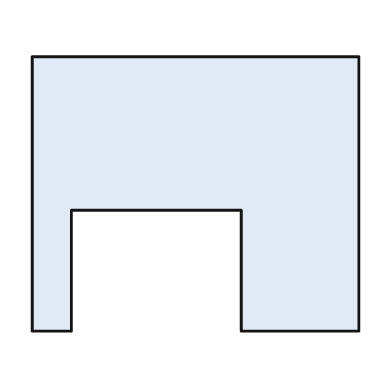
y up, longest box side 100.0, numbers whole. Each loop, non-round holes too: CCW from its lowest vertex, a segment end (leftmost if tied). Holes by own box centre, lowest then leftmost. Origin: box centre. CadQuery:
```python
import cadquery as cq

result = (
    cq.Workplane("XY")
    .moveTo(-50.0, -42.0)
    .lineTo(-38.0, -42.0)
    .lineTo(-38.0, -5.0)
    .lineTo(14.0, -5.0)
    .lineTo(14.0, -42.0)
    .lineTo(50.0, -42.0)
    .lineTo(50.0, 42.0)
    .lineTo(-50.0, 42.0)
    .close()
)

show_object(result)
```